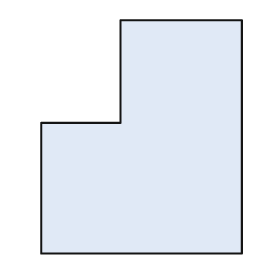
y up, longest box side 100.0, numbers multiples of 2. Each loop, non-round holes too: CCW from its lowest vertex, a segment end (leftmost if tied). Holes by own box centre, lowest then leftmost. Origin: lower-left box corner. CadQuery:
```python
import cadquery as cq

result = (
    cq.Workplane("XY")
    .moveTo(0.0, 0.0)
    .lineTo(86.0, 0.0)
    .lineTo(86.0, 100.0)
    .lineTo(34.0, 100.0)
    .lineTo(34.0, 56.0)
    .lineTo(0.0, 56.0)
    .close()
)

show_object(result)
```